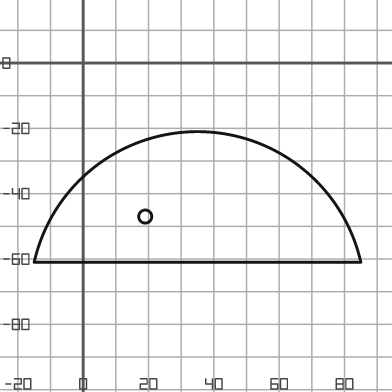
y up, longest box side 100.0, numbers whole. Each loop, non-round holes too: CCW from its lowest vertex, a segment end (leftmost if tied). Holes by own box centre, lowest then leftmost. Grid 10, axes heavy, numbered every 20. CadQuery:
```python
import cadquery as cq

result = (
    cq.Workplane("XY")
    .moveTo(-15.0, -61.0)
    .lineTo(85.0, -61.0)
    .threePointArc((35.0, -21.0), (-15.0, -61.0))
    .close()
    .moveTo(19.0, -47.0)
    .circle(2.0)
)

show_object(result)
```